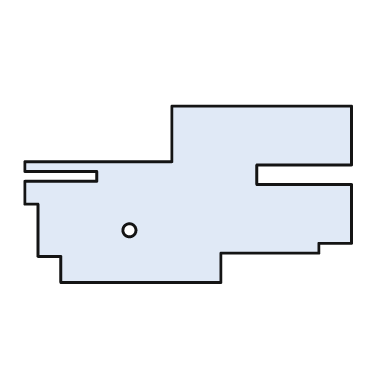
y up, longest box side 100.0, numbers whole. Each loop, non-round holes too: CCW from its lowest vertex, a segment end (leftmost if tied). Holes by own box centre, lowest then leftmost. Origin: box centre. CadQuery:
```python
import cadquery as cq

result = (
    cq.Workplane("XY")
    .moveTo(-39.0, -27.0)
    .lineTo(10.0, -27.0)
    .lineTo(10.0, -18.0)
    .lineTo(40.0, -18.0)
    .lineTo(40.0, -15.0)
    .lineTo(50.0, -15.0)
    .lineTo(50.0, 3.0)
    .lineTo(21.0, 3.0)
    .lineTo(21.0, 9.0)
    .lineTo(50.0, 9.0)
    .lineTo(50.0, 27.0)
    .lineTo(-5.0, 27.0)
    .lineTo(-5.0, 10.0)
    .lineTo(-50.0, 10.0)
    .lineTo(-50.0, 7.0)
    .lineTo(-28.0, 7.0)
    .lineTo(-28.0, 4.0)
    .lineTo(-50.0, 4.0)
    .lineTo(-50.0, -3.0)
    .lineTo(-46.0, -3.0)
    .lineTo(-46.0, -19.0)
    .lineTo(-39.0, -19.0)
    .close()
    .moveTo(-18.0, -11.0)
    .circle(2.0)
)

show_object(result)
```